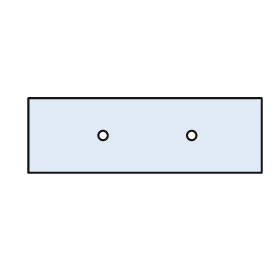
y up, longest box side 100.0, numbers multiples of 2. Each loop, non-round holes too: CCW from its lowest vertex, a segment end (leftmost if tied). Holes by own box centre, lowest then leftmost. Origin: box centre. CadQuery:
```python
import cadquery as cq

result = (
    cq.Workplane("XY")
    .moveTo(-50.0, -16.0)
    .lineTo(50.0, -16.0)
    .lineTo(50.0, 16.0)
    .lineTo(-50.0, 16.0)
    .close()
    .moveTo(-18.0, 0.0)
    .circle(2.0)
    .moveTo(20.0, 0.0)
    .circle(2.0)
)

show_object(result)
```